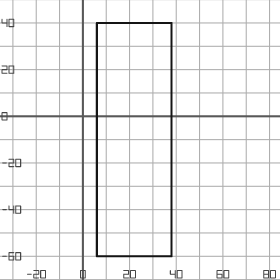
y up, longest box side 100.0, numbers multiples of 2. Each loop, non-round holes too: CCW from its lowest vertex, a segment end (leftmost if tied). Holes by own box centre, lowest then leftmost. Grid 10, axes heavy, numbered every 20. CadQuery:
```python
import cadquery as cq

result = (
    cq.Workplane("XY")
    .moveTo(6.0, -60.0)
    .lineTo(38.0, -60.0)
    .lineTo(38.0, 40.0)
    .lineTo(6.0, 40.0)
    .close()
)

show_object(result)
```